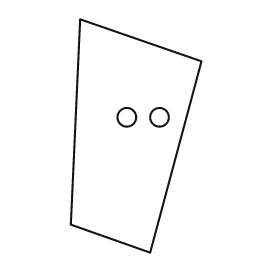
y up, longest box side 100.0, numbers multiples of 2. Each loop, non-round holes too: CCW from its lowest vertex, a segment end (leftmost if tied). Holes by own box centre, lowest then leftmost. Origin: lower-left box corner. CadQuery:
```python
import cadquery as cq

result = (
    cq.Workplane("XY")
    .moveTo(34.0, 0.0)
    .lineTo(56.0, 82.0)
    .lineTo(4.0, 100.0)
    .lineTo(0.0, 12.0)
    .close()
    .moveTo(24.0, 58.0)
    .circle(4.0)
    .moveTo(38.0, 58.0)
    .circle(4.0)
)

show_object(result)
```